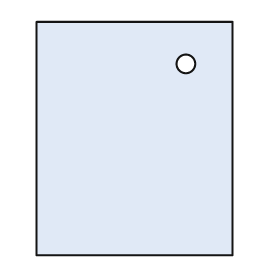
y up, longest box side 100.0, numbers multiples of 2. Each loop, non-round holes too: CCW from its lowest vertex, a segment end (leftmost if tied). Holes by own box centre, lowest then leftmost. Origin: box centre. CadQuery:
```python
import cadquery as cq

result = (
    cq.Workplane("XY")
    .moveTo(-42.0, -50.0)
    .lineTo(42.0, -50.0)
    .lineTo(42.0, 50.0)
    .lineTo(-42.0, 50.0)
    .close()
    .moveTo(22.0, 32.0)
    .circle(4.0)
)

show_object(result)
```